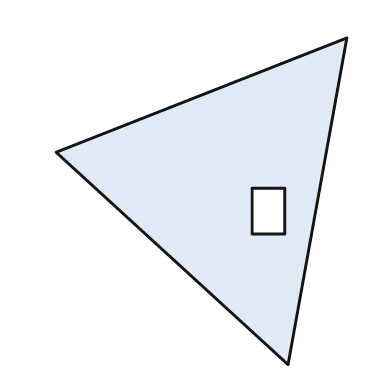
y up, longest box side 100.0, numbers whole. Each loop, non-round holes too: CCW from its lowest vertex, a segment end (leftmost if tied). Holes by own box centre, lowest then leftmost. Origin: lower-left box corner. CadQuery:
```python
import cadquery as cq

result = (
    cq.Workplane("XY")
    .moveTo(71.0, 0.0)
    .lineTo(89.0, 100.0)
    .lineTo(0.0, 65.0)
    .close()
    .moveTo(60.0, 40.0)
    .lineTo(70.0, 40.0)
    .lineTo(70.0, 54.0)
    .lineTo(60.0, 54.0)
    .close()
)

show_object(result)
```